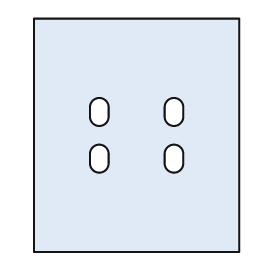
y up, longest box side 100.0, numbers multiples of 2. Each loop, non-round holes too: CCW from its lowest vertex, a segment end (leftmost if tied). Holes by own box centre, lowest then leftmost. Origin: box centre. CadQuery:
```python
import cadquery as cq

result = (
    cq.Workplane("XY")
    .moveTo(-44.0, -50.0)
    .lineTo(44.0, -50.0)
    .lineTo(44.0, 50.0)
    .lineTo(-44.0, 50.0)
    .close()
    .moveTo(-20.0, -12.0)
    .threePointArc((-16.0, -16.0), (-12.0, -12.0))
    .lineTo(-12.0, -8.0)
    .threePointArc((-16.0, -4.0), (-20.0, -8.0))
    .close()
    .moveTo(12.0, -12.0)
    .threePointArc((16.0, -16.0), (20.0, -12.0))
    .lineTo(20.0, -8.0)
    .threePointArc((16.0, -4.0), (12.0, -8.0))
    .close()
    .moveTo(-20.0, 8.0)
    .threePointArc((-16.0, 4.0), (-12.0, 8.0))
    .lineTo(-12.0, 12.0)
    .threePointArc((-16.0, 16.0), (-20.0, 12.0))
    .close()
    .moveTo(12.0, 8.0)
    .threePointArc((16.0, 4.0), (20.0, 8.0))
    .lineTo(20.0, 12.0)
    .threePointArc((16.0, 16.0), (12.0, 12.0))
    .close()
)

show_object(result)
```